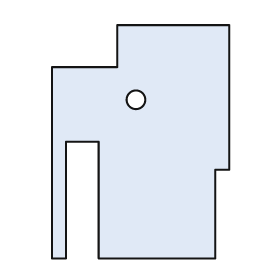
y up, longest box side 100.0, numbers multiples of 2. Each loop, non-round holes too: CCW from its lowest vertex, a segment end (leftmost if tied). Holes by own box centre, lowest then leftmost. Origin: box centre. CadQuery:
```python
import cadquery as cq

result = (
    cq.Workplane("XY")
    .moveTo(-38.0, -50.0)
    .lineTo(-32.0, -50.0)
    .lineTo(-32.0, 0.0)
    .lineTo(-18.0, 0.0)
    .lineTo(-18.0, -50.0)
    .lineTo(32.0, -50.0)
    .lineTo(32.0, -12.0)
    .lineTo(38.0, -12.0)
    .lineTo(38.0, 50.0)
    .lineTo(-10.0, 50.0)
    .lineTo(-10.0, 32.0)
    .lineTo(-38.0, 32.0)
    .close()
    .moveTo(-2.0, 18.0)
    .circle(4.0)
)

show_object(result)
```